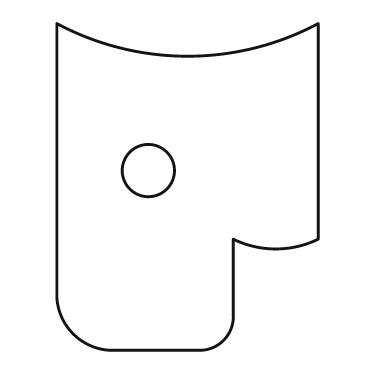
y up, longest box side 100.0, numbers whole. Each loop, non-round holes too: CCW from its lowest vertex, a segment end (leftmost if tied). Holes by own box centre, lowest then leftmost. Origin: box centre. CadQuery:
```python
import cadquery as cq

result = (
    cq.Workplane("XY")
    .moveTo(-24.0, -50.0)
    .lineTo(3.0, -50.0)
    .threePointArc((11.0, -47.0), (14.0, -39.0))
    .lineTo(14.0, -16.0)
    .threePointArc((27.0, -19.0), (40.0, -16.0))
    .lineTo(40.0, 50.0)
    .threePointArc((0.0, 40.0), (-40.0, 50.0))
    .lineTo(-40.0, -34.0)
    .threePointArc((-35.0, -45.0), (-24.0, -50.0))
    .close()
    .moveTo(-12.0, 5.0)
    .circle(8.0)
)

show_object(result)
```